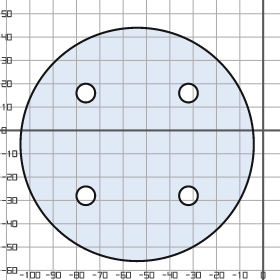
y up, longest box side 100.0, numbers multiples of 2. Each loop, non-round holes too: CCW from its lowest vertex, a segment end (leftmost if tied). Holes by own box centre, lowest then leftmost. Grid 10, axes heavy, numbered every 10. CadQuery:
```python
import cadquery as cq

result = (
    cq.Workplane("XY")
    .moveTo(-54.0, -6.0)
    .circle(50.0)
    .moveTo(-76.0, -28.0)
    .circle(4.0)
    .moveTo(-32.0, -28.0)
    .circle(4.0)
    .moveTo(-76.0, 16.0)
    .circle(4.0)
    .moveTo(-32.0, 16.0)
    .circle(4.0)
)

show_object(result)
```